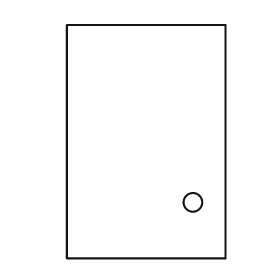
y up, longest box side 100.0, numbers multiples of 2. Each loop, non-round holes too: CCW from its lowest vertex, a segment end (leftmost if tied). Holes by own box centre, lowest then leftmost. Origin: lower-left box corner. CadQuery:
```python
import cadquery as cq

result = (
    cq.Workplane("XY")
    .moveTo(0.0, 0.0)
    .lineTo(68.0, 0.0)
    .lineTo(68.0, 100.0)
    .lineTo(0.0, 100.0)
    .close()
    .moveTo(54.0, 24.0)
    .circle(4.0)
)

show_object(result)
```